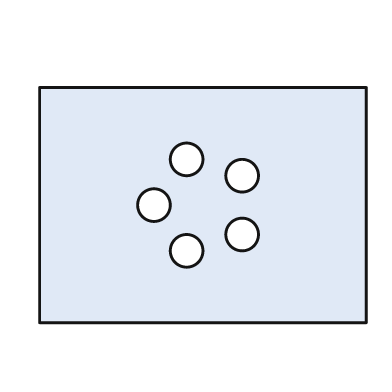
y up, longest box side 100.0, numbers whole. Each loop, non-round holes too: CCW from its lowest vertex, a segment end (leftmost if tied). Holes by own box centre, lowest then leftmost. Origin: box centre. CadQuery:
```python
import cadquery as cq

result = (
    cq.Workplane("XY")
    .moveTo(-50.0, -36.0)
    .lineTo(50.0, -36.0)
    .lineTo(50.0, 36.0)
    .lineTo(-50.0, 36.0)
    .close()
    .moveTo(-5.0, -14.0)
    .circle(5.0)
    .moveTo(12.0, -9.0)
    .circle(5.0)
    .moveTo(-15.0, 0.0)
    .circle(5.0)
    .moveTo(12.0, 9.0)
    .circle(5.0)
    .moveTo(-5.0, 14.0)
    .circle(5.0)
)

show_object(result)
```